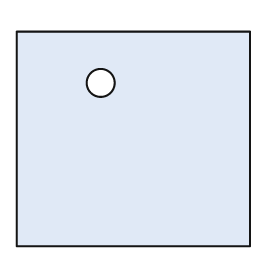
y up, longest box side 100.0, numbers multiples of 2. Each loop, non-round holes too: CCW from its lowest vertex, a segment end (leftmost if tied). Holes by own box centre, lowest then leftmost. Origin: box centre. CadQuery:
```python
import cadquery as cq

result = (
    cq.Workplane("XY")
    .moveTo(-50.0, -46.0)
    .lineTo(50.0, -46.0)
    .lineTo(50.0, 46.0)
    .lineTo(-50.0, 46.0)
    .close()
    .moveTo(-14.0, 24.0)
    .circle(6.0)
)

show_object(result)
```